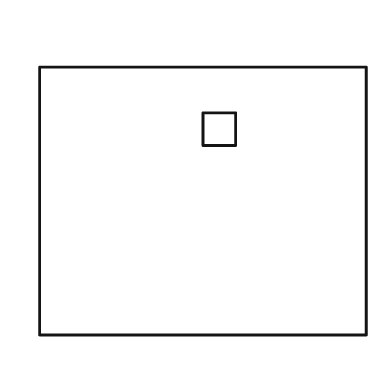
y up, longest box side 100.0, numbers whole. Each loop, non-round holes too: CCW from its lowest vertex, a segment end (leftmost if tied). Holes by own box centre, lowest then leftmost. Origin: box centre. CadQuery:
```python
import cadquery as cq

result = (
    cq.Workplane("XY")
    .moveTo(-50.0, -41.0)
    .lineTo(50.0, -41.0)
    .lineTo(50.0, 41.0)
    .lineTo(-50.0, 41.0)
    .close()
    .moveTo(0.0, 17.0)
    .lineTo(10.0, 17.0)
    .lineTo(10.0, 27.0)
    .lineTo(0.0, 27.0)
    .close()
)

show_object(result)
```